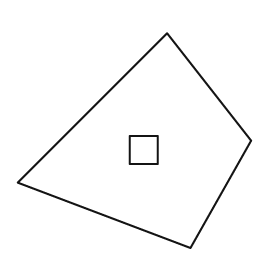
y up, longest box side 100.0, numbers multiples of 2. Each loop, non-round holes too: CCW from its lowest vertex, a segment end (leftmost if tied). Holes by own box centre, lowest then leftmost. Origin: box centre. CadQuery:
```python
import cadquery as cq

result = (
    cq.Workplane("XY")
    .moveTo(24.0, -46.0)
    .lineTo(50.0, 0.0)
    .lineTo(14.0, 46.0)
    .lineTo(-50.0, -18.0)
    .close()
    .moveTo(-2.0, -10.0)
    .lineTo(10.0, -10.0)
    .lineTo(10.0, 2.0)
    .lineTo(-2.0, 2.0)
    .close()
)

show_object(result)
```